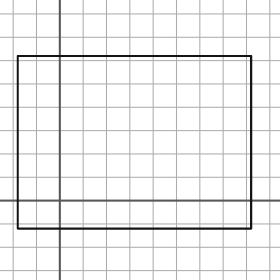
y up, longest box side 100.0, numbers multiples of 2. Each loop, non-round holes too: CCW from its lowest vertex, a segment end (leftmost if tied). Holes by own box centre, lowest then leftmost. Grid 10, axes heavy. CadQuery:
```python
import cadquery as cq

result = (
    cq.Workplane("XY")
    .moveTo(-18.0, -12.0)
    .lineTo(82.0, -12.0)
    .lineTo(82.0, 62.0)
    .lineTo(-18.0, 62.0)
    .close()
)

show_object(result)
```